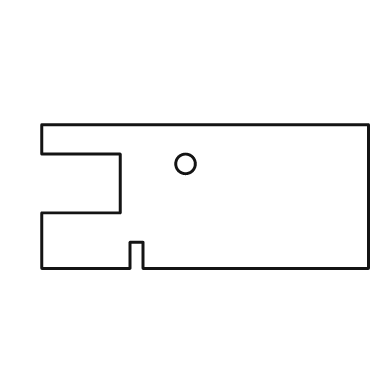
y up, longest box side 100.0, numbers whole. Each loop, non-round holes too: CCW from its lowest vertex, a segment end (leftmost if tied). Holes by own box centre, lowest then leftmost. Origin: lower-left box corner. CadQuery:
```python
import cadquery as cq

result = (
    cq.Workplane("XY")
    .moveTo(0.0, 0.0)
    .lineTo(27.0, 0.0)
    .lineTo(27.0, 8.0)
    .lineTo(31.0, 8.0)
    .lineTo(31.0, 0.0)
    .lineTo(100.0, 0.0)
    .lineTo(100.0, 44.0)
    .lineTo(0.0, 44.0)
    .lineTo(0.0, 35.0)
    .lineTo(24.0, 35.0)
    .lineTo(24.0, 17.0)
    .lineTo(0.0, 17.0)
    .close()
    .moveTo(44.0, 32.0)
    .circle(3.0)
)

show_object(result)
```